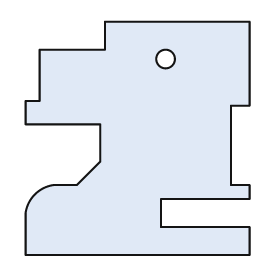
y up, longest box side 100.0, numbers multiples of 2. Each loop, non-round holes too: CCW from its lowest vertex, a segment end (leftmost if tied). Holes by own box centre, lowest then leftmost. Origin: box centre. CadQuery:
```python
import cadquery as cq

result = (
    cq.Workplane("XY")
    .moveTo(-48.0, -50.0)
    .lineTo(48.0, -50.0)
    .lineTo(48.0, -38.0)
    .lineTo(10.0, -38.0)
    .lineTo(10.0, -26.0)
    .lineTo(48.0, -26.0)
    .lineTo(48.0, -20.0)
    .lineTo(40.0, -20.0)
    .lineTo(40.0, 14.0)
    .lineTo(48.0, 14.0)
    .lineTo(48.0, 50.0)
    .lineTo(-14.0, 50.0)
    .lineTo(-14.0, 38.0)
    .lineTo(-42.0, 38.0)
    .lineTo(-42.0, 16.0)
    .lineTo(-48.0, 16.0)
    .lineTo(-48.0, 6.0)
    .lineTo(-16.0, 6.0)
    .lineTo(-16.0, -10.0)
    .lineTo(-26.0, -20.0)
    .lineTo(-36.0, -20.0)
    .threePointArc((-44.0, -24.0), (-48.0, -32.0))
    .close()
    .moveTo(12.0, 34.0)
    .circle(4.0)
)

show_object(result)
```